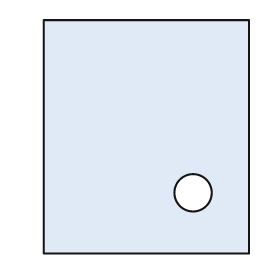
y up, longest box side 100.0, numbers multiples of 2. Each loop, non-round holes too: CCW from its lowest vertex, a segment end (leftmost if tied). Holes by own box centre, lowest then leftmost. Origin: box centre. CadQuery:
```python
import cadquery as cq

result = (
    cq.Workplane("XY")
    .moveTo(-44.0, -50.0)
    .lineTo(44.0, -50.0)
    .lineTo(44.0, 50.0)
    .lineTo(-44.0, 50.0)
    .close()
    .moveTo(20.0, -24.0)
    .circle(8.0)
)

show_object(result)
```